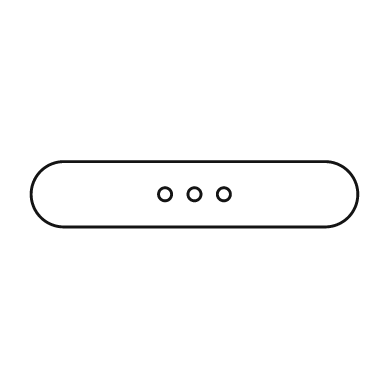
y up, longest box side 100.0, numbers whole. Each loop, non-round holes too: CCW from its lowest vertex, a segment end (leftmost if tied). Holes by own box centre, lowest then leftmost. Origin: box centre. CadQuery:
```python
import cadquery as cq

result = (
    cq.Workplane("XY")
    .moveTo(-40.0, -10.0)
    .lineTo(40.0, -10.0)
    .threePointArc((50.0, 0.0), (40.0, 10.0))
    .lineTo(-40.0, 10.0)
    .threePointArc((-50.0, 0.0), (-40.0, -10.0))
    .close()
    .moveTo(-9.0, 0.0)
    .circle(2.0)
    .moveTo(0.0, 0.0)
    .circle(2.0)
    .moveTo(9.0, 0.0)
    .circle(2.0)
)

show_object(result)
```